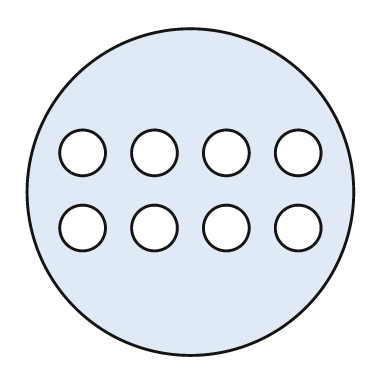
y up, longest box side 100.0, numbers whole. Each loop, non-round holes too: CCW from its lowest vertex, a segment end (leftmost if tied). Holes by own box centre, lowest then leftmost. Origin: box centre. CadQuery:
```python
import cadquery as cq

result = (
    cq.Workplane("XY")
    .moveTo(0.0, 0.0)
    .circle(50.0)
    .moveTo(-33.0, -11.0)
    .circle(7.0)
    .moveTo(-11.0, -11.0)
    .circle(7.0)
    .moveTo(11.0, -11.0)
    .circle(7.0)
    .moveTo(33.0, -11.0)
    .circle(7.0)
    .moveTo(-33.0, 12.0)
    .circle(7.0)
    .moveTo(-11.0, 12.0)
    .circle(7.0)
    .moveTo(11.0, 12.0)
    .circle(7.0)
    .moveTo(33.0, 12.0)
    .circle(7.0)
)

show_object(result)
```